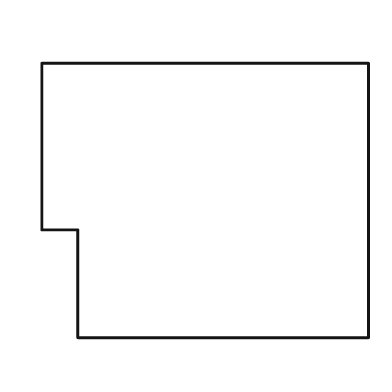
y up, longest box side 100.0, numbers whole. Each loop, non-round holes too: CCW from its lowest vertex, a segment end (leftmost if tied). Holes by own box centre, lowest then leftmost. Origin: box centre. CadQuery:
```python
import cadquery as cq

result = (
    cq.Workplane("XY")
    .moveTo(-39.0, -42.0)
    .lineTo(50.0, -42.0)
    .lineTo(50.0, 42.0)
    .lineTo(-50.0, 42.0)
    .lineTo(-50.0, -9.0)
    .lineTo(-39.0, -9.0)
    .close()
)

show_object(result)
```